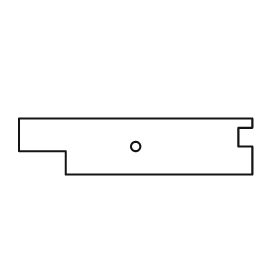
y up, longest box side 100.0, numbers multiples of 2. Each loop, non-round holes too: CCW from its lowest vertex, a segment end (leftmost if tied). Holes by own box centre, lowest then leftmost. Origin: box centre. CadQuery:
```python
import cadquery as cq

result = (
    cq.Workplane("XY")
    .moveTo(-30.0, -12.0)
    .lineTo(50.0, -12.0)
    .lineTo(50.0, 0.0)
    .lineTo(44.0, 0.0)
    .lineTo(44.0, 8.0)
    .lineTo(50.0, 8.0)
    .lineTo(50.0, 12.0)
    .lineTo(-50.0, 12.0)
    .lineTo(-50.0, -2.0)
    .lineTo(-30.0, -2.0)
    .close()
    .moveTo(0.0, 0.0)
    .circle(2.0)
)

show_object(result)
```